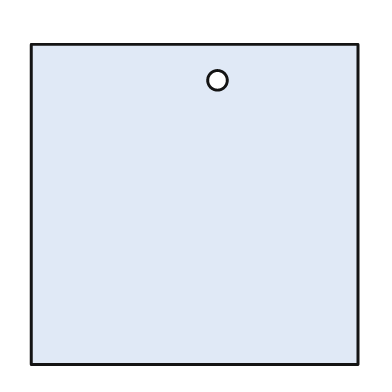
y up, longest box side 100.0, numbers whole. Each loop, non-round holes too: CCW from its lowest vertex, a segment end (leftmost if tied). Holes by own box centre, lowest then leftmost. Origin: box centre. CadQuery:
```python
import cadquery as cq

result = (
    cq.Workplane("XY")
    .moveTo(-50.0, -49.0)
    .lineTo(50.0, -49.0)
    .lineTo(50.0, 49.0)
    .lineTo(-50.0, 49.0)
    .close()
    .moveTo(7.0, 38.0)
    .circle(3.0)
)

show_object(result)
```